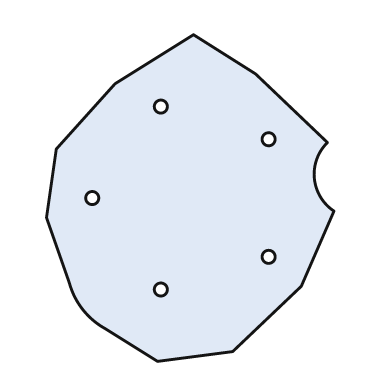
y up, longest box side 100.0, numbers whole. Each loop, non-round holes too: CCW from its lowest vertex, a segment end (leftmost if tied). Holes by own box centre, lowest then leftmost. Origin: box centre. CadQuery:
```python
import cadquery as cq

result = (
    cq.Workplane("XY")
    .moveTo(-10.0, -50.0)
    .lineTo(13.0, -47.0)
    .lineTo(34.0, -27.0)
    .lineTo(44.0, -4.0)
    .threePointArc((38.0, 6.0), (42.0, 17.0))
    .lineTo(20.0, 38.0)
    .lineTo(1.0, 50.0)
    .lineTo(-23.0, 35.0)
    .lineTo(-41.0, 15.0)
    .lineTo(-44.0, -6.0)
    .lineTo(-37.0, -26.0)
    .threePointArc((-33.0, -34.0), (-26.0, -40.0))
    .close()
    .moveTo(-9.0, -28.0)
    .circle(2.0)
    .moveTo(24.0, -18.0)
    .circle(2.0)
    .moveTo(-30.0, 0.0)
    .circle(2.0)
    .moveTo(24.0, 18.0)
    .circle(2.0)
    .moveTo(-9.0, 28.0)
    .circle(2.0)
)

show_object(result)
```